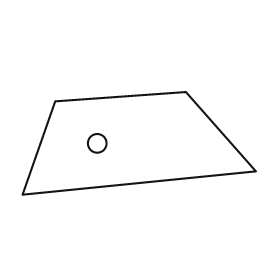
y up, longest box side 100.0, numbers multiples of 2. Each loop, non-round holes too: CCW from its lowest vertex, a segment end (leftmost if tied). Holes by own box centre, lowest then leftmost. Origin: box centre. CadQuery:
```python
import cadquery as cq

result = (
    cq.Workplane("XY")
    .moveTo(-50.0, -22.0)
    .lineTo(50.0, -12.0)
    .lineTo(20.0, 22.0)
    .lineTo(-36.0, 18.0)
    .close()
    .moveTo(-18.0, 0.0)
    .circle(4.0)
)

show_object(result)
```